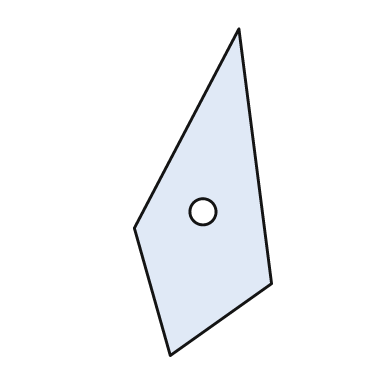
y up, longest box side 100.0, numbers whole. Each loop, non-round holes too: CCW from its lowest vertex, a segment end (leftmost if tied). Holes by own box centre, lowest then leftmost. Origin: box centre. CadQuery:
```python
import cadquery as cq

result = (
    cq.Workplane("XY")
    .moveTo(-10.0, -50.0)
    .lineTo(21.0, -28.0)
    .lineTo(11.0, 50.0)
    .lineTo(-21.0, -11.0)
    .close()
    .moveTo(0.0, -6.0)
    .circle(4.0)
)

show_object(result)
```